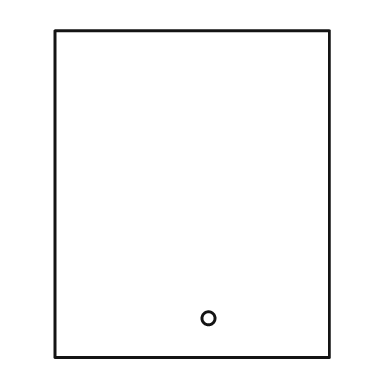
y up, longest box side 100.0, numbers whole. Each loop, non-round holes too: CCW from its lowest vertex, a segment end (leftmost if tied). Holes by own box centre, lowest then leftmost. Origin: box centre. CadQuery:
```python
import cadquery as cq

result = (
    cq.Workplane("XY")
    .moveTo(-42.0, -50.0)
    .lineTo(42.0, -50.0)
    .lineTo(42.0, 50.0)
    .lineTo(-42.0, 50.0)
    .close()
    .moveTo(5.0, -38.0)
    .circle(2.0)
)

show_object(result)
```